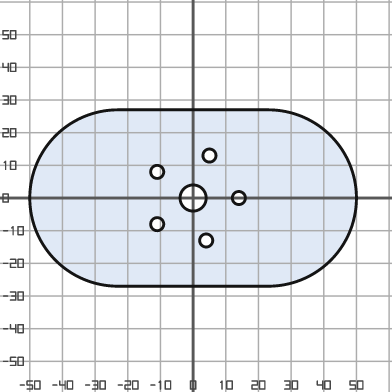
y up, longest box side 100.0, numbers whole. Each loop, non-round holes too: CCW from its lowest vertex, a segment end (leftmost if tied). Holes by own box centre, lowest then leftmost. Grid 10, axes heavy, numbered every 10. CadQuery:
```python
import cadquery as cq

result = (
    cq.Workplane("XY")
    .moveTo(-23.0, -27.0)
    .lineTo(23.0, -27.0)
    .threePointArc((50.0, 0.0), (23.0, 27.0))
    .lineTo(-23.0, 27.0)
    .threePointArc((-50.0, 0.0), (-23.0, -27.0))
    .close()
    .moveTo(4.0, -13.0)
    .circle(2.0)
    .moveTo(-11.0, -8.0)
    .circle(2.0)
    .moveTo(0.0, 0.0)
    .circle(4.0)
    .moveTo(14.0, 0.0)
    .circle(2.0)
    .moveTo(-11.0, 8.0)
    .circle(2.0)
    .moveTo(5.0, 13.0)
    .circle(2.0)
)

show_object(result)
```